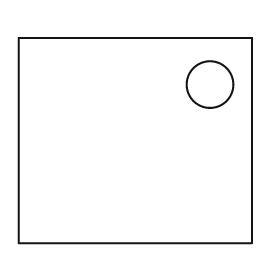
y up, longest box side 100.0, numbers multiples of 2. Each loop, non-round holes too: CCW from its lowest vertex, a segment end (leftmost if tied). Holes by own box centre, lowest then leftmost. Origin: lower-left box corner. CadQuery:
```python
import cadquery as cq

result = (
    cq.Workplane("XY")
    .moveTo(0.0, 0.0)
    .lineTo(100.0, 0.0)
    .lineTo(100.0, 88.0)
    .lineTo(0.0, 88.0)
    .close()
    .moveTo(82.0, 68.0)
    .circle(10.0)
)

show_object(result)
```